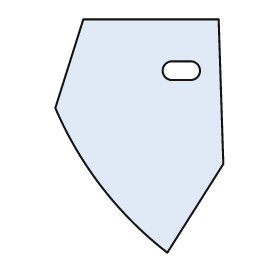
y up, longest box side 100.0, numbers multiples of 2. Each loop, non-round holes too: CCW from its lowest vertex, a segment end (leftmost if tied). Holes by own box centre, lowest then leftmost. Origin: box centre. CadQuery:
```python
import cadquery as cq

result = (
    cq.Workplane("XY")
    .moveTo(12.0, -50.0)
    .lineTo(36.0, -12.0)
    .lineTo(34.0, 50.0)
    .lineTo(-24.0, 50.0)
    .lineTo(-36.0, 12.0)
    .threePointArc((-16.0, -22.0), (12.0, -50.0))
    .close()
    .moveTo(14.0, 24.0)
    .lineTo(22.0, 24.0)
    .threePointArc((26.0, 28.0), (22.0, 32.0))
    .lineTo(14.0, 32.0)
    .threePointArc((10.0, 28.0), (14.0, 24.0))
    .close()
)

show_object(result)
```